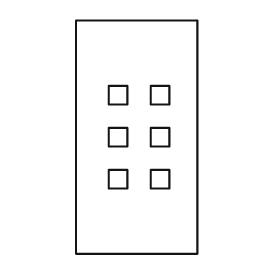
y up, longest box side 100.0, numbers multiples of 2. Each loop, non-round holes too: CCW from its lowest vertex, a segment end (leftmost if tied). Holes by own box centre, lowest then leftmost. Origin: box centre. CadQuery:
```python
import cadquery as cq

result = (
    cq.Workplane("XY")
    .moveTo(-26.0, -50.0)
    .lineTo(26.0, -50.0)
    .lineTo(26.0, 50.0)
    .lineTo(-26.0, 50.0)
    .close()
    .moveTo(-12.0, -22.0)
    .lineTo(-4.0, -22.0)
    .lineTo(-4.0, -14.0)
    .lineTo(-12.0, -14.0)
    .close()
    .moveTo(6.0, -22.0)
    .lineTo(14.0, -22.0)
    .lineTo(14.0, -14.0)
    .lineTo(6.0, -14.0)
    .close()
    .moveTo(-12.0, -4.0)
    .lineTo(-4.0, -4.0)
    .lineTo(-4.0, 4.0)
    .lineTo(-12.0, 4.0)
    .close()
    .moveTo(6.0, -4.0)
    .lineTo(14.0, -4.0)
    .lineTo(14.0, 4.0)
    .lineTo(6.0, 4.0)
    .close()
    .moveTo(-12.0, 14.0)
    .lineTo(-4.0, 14.0)
    .lineTo(-4.0, 22.0)
    .lineTo(-12.0, 22.0)
    .close()
    .moveTo(6.0, 14.0)
    .lineTo(14.0, 14.0)
    .lineTo(14.0, 22.0)
    .lineTo(6.0, 22.0)
    .close()
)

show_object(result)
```